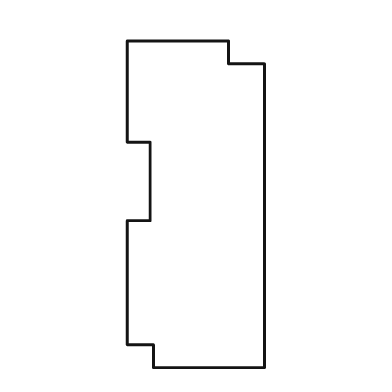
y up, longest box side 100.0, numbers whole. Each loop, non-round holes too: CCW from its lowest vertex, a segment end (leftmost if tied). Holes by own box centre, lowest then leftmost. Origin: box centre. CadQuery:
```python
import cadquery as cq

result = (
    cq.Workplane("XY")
    .moveTo(-13.0, -50.0)
    .lineTo(21.0, -50.0)
    .lineTo(21.0, 43.0)
    .lineTo(10.0, 43.0)
    .lineTo(10.0, 50.0)
    .lineTo(-21.0, 50.0)
    .lineTo(-21.0, 19.0)
    .lineTo(-14.0, 19.0)
    .lineTo(-14.0, -5.0)
    .lineTo(-21.0, -5.0)
    .lineTo(-21.0, -43.0)
    .lineTo(-13.0, -43.0)
    .close()
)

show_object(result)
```